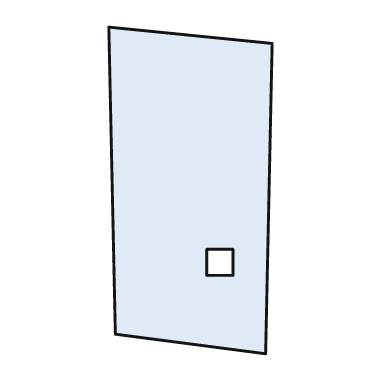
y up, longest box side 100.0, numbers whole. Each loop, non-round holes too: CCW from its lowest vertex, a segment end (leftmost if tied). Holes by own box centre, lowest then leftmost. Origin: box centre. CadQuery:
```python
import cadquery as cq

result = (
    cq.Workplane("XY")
    .moveTo(23.0, -50.0)
    .lineTo(25.0, 45.0)
    .lineTo(-25.0, 50.0)
    .lineTo(-23.0, -44.0)
    .close()
    .moveTo(5.0, -26.0)
    .lineTo(13.0, -26.0)
    .lineTo(13.0, -18.0)
    .lineTo(5.0, -18.0)
    .close()
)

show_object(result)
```